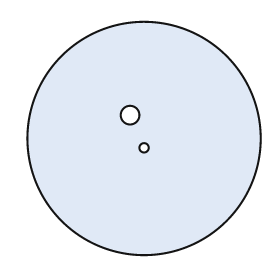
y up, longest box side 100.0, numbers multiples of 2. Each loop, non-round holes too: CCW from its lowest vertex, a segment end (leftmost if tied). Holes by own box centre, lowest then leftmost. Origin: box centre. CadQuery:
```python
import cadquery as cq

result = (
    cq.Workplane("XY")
    .moveTo(0.0, 0.0)
    .circle(50.0)
    .moveTo(0.0, -4.0)
    .circle(2.0)
    .moveTo(-6.0, 10.0)
    .circle(4.0)
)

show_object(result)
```